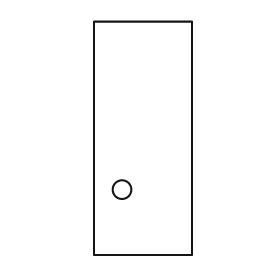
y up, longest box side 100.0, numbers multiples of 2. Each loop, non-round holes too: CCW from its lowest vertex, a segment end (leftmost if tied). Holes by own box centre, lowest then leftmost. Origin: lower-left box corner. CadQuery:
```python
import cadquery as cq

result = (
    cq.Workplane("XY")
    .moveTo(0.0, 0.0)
    .lineTo(42.0, 0.0)
    .lineTo(42.0, 100.0)
    .lineTo(0.0, 100.0)
    .close()
    .moveTo(12.0, 28.0)
    .circle(4.0)
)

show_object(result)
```